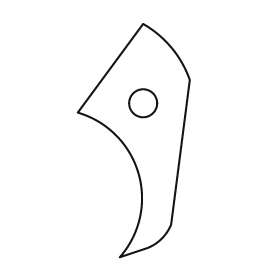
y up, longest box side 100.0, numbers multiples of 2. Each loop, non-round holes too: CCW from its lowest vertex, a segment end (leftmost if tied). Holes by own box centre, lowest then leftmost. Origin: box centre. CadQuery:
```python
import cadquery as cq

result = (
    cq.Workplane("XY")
    .moveTo(-6.0, -50.0)
    .lineTo(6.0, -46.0)
    .threePointArc((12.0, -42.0), (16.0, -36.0))
    .lineTo(24.0, 26.0)
    .threePointArc((16.0, 40.0), (4.0, 50.0))
    .lineTo(-24.0, 12.0)
    .threePointArc((2.0, -14.0), (-6.0, -50.0))
    .close()
    .moveTo(4.0, 16.0)
    .circle(6.0)
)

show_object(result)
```